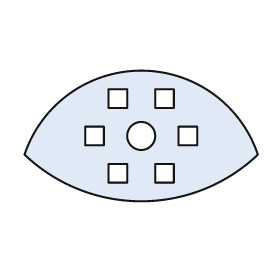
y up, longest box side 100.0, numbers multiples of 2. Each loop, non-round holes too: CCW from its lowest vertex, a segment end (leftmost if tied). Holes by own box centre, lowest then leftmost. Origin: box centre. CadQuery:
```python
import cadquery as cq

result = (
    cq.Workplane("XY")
    .moveTo(-50.0, -8.0)
    .threePointArc((0.0, -28.0), (50.0, -8.0))
    .threePointArc((0.0, 28.0), (-50.0, -8.0))
    .close()
    .moveTo(-14.0, -20.0)
    .lineTo(-6.0, -20.0)
    .lineTo(-6.0, -12.0)
    .lineTo(-14.0, -12.0)
    .close()
    .moveTo(6.0, -20.0)
    .lineTo(14.0, -20.0)
    .lineTo(14.0, -12.0)
    .lineTo(6.0, -12.0)
    .close()
    .moveTo(-24.0, -4.0)
    .lineTo(-16.0, -4.0)
    .lineTo(-16.0, 4.0)
    .lineTo(-24.0, 4.0)
    .close()
    .moveTo(0.0, 0.0)
    .circle(6.0)
    .moveTo(16.0, -4.0)
    .lineTo(24.0, -4.0)
    .lineTo(24.0, 4.0)
    .lineTo(16.0, 4.0)
    .close()
    .moveTo(-14.0, 12.0)
    .lineTo(-6.0, 12.0)
    .lineTo(-6.0, 20.0)
    .lineTo(-14.0, 20.0)
    .close()
    .moveTo(6.0, 12.0)
    .lineTo(14.0, 12.0)
    .lineTo(14.0, 20.0)
    .lineTo(6.0, 20.0)
    .close()
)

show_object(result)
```